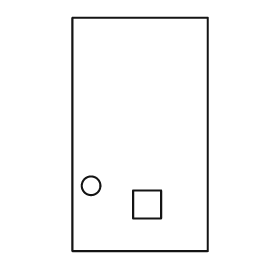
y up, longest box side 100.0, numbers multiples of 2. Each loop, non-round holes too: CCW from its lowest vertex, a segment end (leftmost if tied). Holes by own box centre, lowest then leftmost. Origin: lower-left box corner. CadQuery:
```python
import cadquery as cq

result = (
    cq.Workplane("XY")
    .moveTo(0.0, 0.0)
    .lineTo(58.0, 0.0)
    .lineTo(58.0, 100.0)
    .lineTo(0.0, 100.0)
    .close()
    .moveTo(26.0, 14.0)
    .lineTo(38.0, 14.0)
    .lineTo(38.0, 26.0)
    .lineTo(26.0, 26.0)
    .close()
    .moveTo(8.0, 28.0)
    .circle(4.0)
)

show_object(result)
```